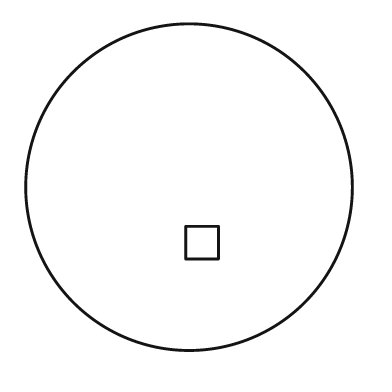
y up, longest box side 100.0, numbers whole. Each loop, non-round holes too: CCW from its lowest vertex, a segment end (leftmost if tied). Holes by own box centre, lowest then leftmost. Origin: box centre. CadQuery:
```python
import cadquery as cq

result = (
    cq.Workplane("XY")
    .moveTo(0.0, 0.0)
    .circle(50.0)
    .moveTo(-1.0, -22.0)
    .lineTo(9.0, -22.0)
    .lineTo(9.0, -12.0)
    .lineTo(-1.0, -12.0)
    .close()
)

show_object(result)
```